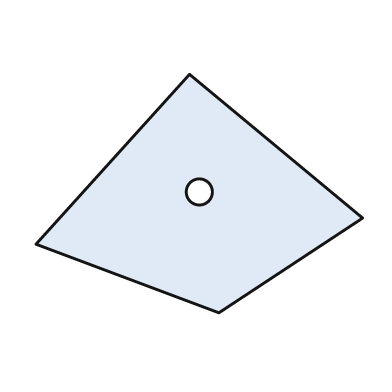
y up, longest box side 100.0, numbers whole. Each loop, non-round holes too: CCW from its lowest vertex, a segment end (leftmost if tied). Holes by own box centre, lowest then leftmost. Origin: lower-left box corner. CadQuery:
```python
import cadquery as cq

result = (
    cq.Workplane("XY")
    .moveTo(56.0, 0.0)
    .lineTo(100.0, 29.0)
    .lineTo(47.0, 73.0)
    .lineTo(0.0, 21.0)
    .close()
    .moveTo(50.0, 37.0)
    .circle(4.0)
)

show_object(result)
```